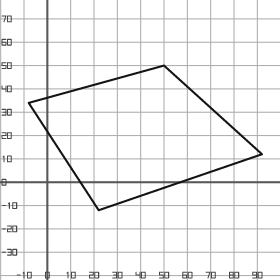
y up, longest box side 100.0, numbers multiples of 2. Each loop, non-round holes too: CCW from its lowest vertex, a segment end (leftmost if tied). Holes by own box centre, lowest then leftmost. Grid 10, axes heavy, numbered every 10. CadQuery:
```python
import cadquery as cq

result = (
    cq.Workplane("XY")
    .moveTo(22.0, -12.0)
    .lineTo(92.0, 12.0)
    .lineTo(50.0, 50.0)
    .lineTo(-8.0, 34.0)
    .close()
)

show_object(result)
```